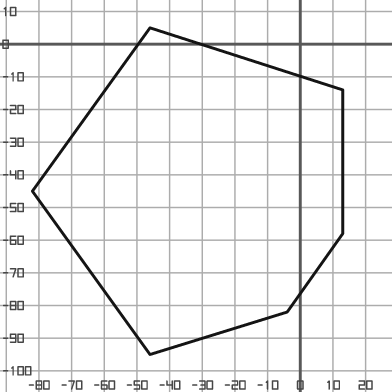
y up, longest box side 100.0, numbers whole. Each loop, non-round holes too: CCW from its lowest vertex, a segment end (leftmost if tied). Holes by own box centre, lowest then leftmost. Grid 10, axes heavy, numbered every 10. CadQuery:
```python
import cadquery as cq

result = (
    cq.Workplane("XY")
    .moveTo(-46.0, -95.0)
    .lineTo(-4.0, -82.0)
    .lineTo(13.0, -58.0)
    .lineTo(13.0, -14.0)
    .lineTo(-46.0, 5.0)
    .lineTo(-82.0, -45.0)
    .close()
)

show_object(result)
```